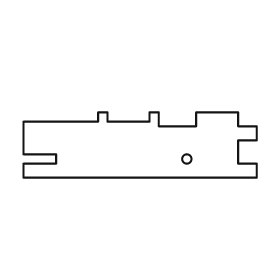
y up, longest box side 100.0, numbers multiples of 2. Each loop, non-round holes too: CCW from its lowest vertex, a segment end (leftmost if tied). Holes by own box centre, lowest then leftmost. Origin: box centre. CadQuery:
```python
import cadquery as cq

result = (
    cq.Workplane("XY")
    .moveTo(-50.0, -14.0)
    .lineTo(50.0, -14.0)
    .lineTo(50.0, -8.0)
    .lineTo(42.0, -8.0)
    .lineTo(42.0, 2.0)
    .lineTo(50.0, 2.0)
    .lineTo(50.0, 8.0)
    .lineTo(42.0, 8.0)
    .lineTo(42.0, 14.0)
    .lineTo(24.0, 14.0)
    .lineTo(24.0, 8.0)
    .lineTo(8.0, 8.0)
    .lineTo(8.0, 14.0)
    .lineTo(4.0, 14.0)
    .lineTo(4.0, 10.0)
    .lineTo(-14.0, 10.0)
    .lineTo(-14.0, 14.0)
    .lineTo(-18.0, 14.0)
    .lineTo(-18.0, 10.0)
    .lineTo(-50.0, 10.0)
    .lineTo(-50.0, -4.0)
    .lineTo(-36.0, -4.0)
    .lineTo(-36.0, -8.0)
    .lineTo(-50.0, -8.0)
    .close()
    .moveTo(20.0, -6.0)
    .circle(2.0)
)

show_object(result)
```